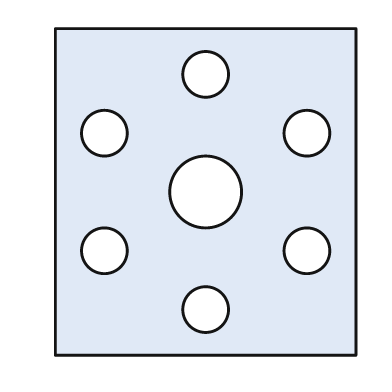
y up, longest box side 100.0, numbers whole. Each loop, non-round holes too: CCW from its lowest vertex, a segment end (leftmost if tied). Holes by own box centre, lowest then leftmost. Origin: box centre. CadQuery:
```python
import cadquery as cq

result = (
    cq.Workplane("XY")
    .moveTo(-46.0, -50.0)
    .lineTo(46.0, -50.0)
    .lineTo(46.0, 50.0)
    .lineTo(-46.0, 50.0)
    .close()
    .moveTo(0.0, -36.0)
    .circle(7.0)
    .moveTo(-31.0, -18.0)
    .circle(7.0)
    .moveTo(31.0, -18.0)
    .circle(7.0)
    .moveTo(0.0, 0.0)
    .circle(11.0)
    .moveTo(-31.0, 18.0)
    .circle(7.0)
    .moveTo(31.0, 18.0)
    .circle(7.0)
    .moveTo(0.0, 36.0)
    .circle(7.0)
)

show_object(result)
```